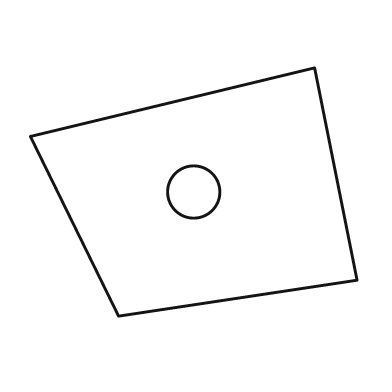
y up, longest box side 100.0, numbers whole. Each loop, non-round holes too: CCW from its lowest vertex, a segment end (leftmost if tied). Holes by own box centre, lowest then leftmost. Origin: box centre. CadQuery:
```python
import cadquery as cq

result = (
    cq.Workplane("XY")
    .moveTo(-23.0, -38.0)
    .lineTo(50.0, -27.0)
    .lineTo(37.0, 38.0)
    .lineTo(-50.0, 17.0)
    .close()
    .moveTo(0.0, 0.0)
    .circle(8.0)
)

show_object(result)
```